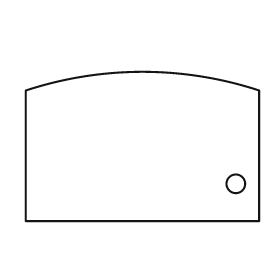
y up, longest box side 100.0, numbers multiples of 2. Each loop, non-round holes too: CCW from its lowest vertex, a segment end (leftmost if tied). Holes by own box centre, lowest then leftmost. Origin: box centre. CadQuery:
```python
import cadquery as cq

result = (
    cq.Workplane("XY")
    .moveTo(-50.0, -32.0)
    .lineTo(50.0, -32.0)
    .lineTo(50.0, 24.0)
    .threePointArc((0.0, 32.0), (-50.0, 24.0))
    .close()
    .moveTo(40.0, -16.0)
    .circle(4.0)
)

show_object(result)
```